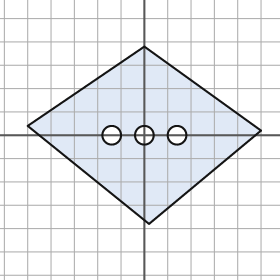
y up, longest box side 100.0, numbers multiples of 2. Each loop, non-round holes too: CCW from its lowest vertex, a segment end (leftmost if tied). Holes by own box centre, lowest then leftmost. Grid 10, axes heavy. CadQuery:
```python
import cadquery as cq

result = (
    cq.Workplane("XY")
    .moveTo(2.0, -38.0)
    .lineTo(50.0, 2.0)
    .lineTo(0.0, 38.0)
    .lineTo(-50.0, 4.0)
    .close()
    .moveTo(-14.0, 0.0)
    .circle(4.0)
    .moveTo(0.0, 0.0)
    .circle(4.0)
    .moveTo(14.0, 0.0)
    .circle(4.0)
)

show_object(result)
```